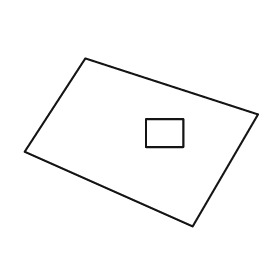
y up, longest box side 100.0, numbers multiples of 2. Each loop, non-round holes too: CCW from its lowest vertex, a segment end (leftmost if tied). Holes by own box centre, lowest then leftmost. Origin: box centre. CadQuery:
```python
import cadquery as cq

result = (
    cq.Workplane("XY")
    .moveTo(22.0, -36.0)
    .lineTo(50.0, 12.0)
    .lineTo(-24.0, 36.0)
    .lineTo(-50.0, -4.0)
    .close()
    .moveTo(2.0, -2.0)
    .lineTo(18.0, -2.0)
    .lineTo(18.0, 10.0)
    .lineTo(2.0, 10.0)
    .close()
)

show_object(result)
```